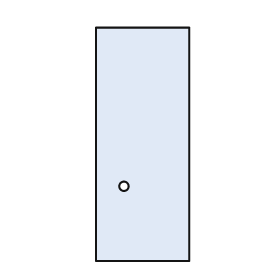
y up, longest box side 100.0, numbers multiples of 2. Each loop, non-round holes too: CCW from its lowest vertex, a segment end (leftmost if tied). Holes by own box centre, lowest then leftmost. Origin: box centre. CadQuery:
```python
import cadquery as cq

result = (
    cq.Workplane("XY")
    .moveTo(-20.0, -50.0)
    .lineTo(20.0, -50.0)
    .lineTo(20.0, 50.0)
    .lineTo(-20.0, 50.0)
    .close()
    .moveTo(-8.0, -18.0)
    .circle(2.0)
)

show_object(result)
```